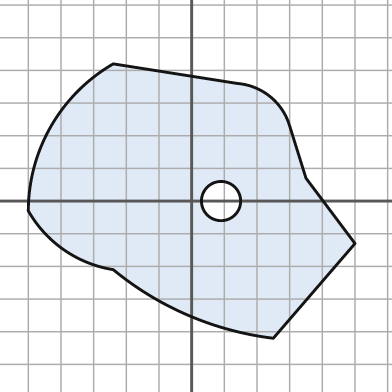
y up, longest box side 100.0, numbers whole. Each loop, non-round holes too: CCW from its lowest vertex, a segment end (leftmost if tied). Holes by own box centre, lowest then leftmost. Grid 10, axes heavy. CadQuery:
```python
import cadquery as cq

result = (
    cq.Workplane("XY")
    .moveTo(25.0, -42.0)
    .lineTo(50.0, -13.0)
    .lineTo(35.0, 7.0)
    .lineTo(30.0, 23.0)
    .threePointArc((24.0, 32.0), (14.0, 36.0))
    .lineTo(-24.0, 42.0)
    .threePointArc((-43.0, 23.0), (-50.0, -3.0))
    .threePointArc((-39.0, -15.0), (-24.0, -21.0))
    .threePointArc((-1.0, -35.0), (25.0, -42.0))
    .close()
    .moveTo(9.0, 0.0)
    .circle(6.0)
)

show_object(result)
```